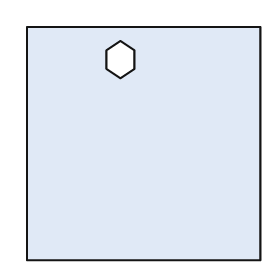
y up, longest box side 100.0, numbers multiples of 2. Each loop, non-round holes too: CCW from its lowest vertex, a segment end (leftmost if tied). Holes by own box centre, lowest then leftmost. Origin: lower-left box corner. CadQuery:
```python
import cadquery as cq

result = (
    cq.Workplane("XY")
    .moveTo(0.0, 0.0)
    .lineTo(100.0, 0.0)
    .lineTo(100.0, 100.0)
    .lineTo(0.0, 100.0)
    .close()
    .moveTo(40.0, 78.0)
    .lineTo(46.0, 82.0)
    .lineTo(46.0, 90.0)
    .lineTo(40.0, 94.0)
    .lineTo(34.0, 90.0)
    .lineTo(34.0, 82.0)
    .close()
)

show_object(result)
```